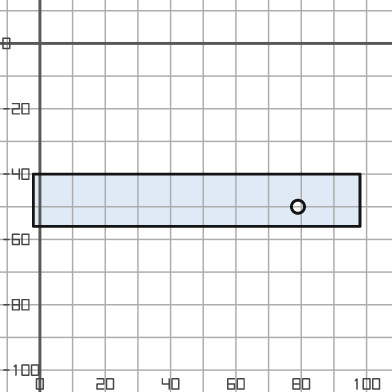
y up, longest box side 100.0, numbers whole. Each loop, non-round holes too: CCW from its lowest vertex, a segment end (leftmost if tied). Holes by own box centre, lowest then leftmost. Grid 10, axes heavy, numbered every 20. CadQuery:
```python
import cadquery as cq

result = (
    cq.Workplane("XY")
    .moveTo(-2.0, -56.0)
    .lineTo(98.0, -56.0)
    .lineTo(98.0, -40.0)
    .lineTo(-2.0, -40.0)
    .close()
    .moveTo(79.0, -50.0)
    .circle(2.0)
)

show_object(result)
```